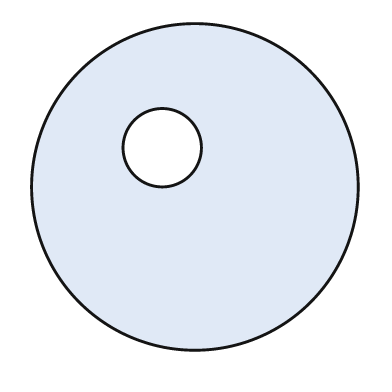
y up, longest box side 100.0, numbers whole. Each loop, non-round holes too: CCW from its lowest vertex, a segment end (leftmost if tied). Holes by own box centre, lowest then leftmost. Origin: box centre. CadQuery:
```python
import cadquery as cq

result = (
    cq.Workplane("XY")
    .moveTo(0.0, 0.0)
    .circle(50.0)
    .moveTo(-10.0, 12.0)
    .circle(12.0)
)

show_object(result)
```